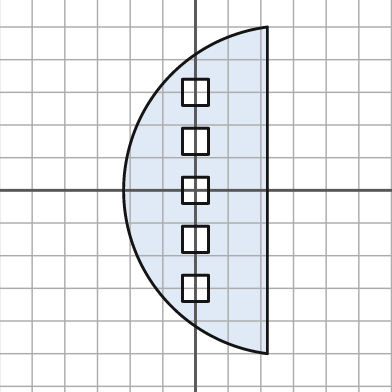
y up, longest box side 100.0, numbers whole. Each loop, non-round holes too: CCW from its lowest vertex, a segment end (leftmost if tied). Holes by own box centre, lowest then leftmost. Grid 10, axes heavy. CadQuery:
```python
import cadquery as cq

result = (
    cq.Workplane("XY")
    .moveTo(22.0, -50.0)
    .lineTo(22.0, 50.0)
    .threePointArc((-22.0, 0.0), (22.0, -50.0))
    .close()
    .moveTo(-4.0, -34.0)
    .lineTo(4.0, -34.0)
    .lineTo(4.0, -26.0)
    .lineTo(-4.0, -26.0)
    .close()
    .moveTo(-4.0, -19.0)
    .lineTo(4.0, -19.0)
    .lineTo(4.0, -11.0)
    .lineTo(-4.0, -11.0)
    .close()
    .moveTo(-4.0, -4.0)
    .lineTo(4.0, -4.0)
    .lineTo(4.0, 4.0)
    .lineTo(-4.0, 4.0)
    .close()
    .moveTo(-4.0, 11.0)
    .lineTo(4.0, 11.0)
    .lineTo(4.0, 19.0)
    .lineTo(-4.0, 19.0)
    .close()
    .moveTo(-4.0, 26.0)
    .lineTo(4.0, 26.0)
    .lineTo(4.0, 34.0)
    .lineTo(-4.0, 34.0)
    .close()
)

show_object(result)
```